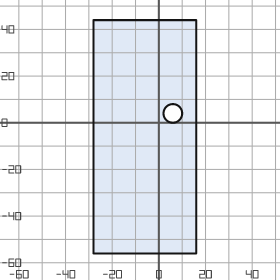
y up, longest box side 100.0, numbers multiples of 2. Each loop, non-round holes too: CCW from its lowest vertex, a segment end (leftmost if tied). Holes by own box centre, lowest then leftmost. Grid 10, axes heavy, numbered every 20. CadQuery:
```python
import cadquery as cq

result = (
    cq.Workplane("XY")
    .moveTo(-28.0, -56.0)
    .lineTo(16.0, -56.0)
    .lineTo(16.0, 44.0)
    .lineTo(-28.0, 44.0)
    .close()
    .moveTo(6.0, 4.0)
    .circle(4.0)
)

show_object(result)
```